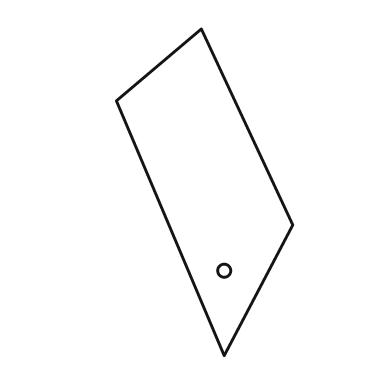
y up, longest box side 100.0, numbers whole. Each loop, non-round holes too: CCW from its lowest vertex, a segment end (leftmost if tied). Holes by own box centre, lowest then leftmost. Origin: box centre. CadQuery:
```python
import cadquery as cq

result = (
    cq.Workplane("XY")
    .moveTo(6.0, -50.0)
    .lineTo(27.0, -10.0)
    .lineTo(-1.0, 50.0)
    .lineTo(-27.0, 28.0)
    .close()
    .moveTo(6.0, -24.0)
    .circle(2.0)
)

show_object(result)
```